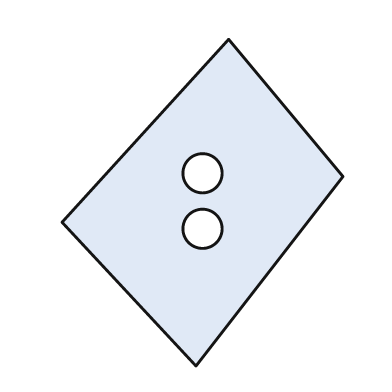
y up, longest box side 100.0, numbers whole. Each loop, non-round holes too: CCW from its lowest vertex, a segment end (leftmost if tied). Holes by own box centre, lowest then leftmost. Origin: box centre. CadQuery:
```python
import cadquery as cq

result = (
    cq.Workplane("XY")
    .moveTo(-2.0, -50.0)
    .lineTo(43.0, 8.0)
    .lineTo(8.0, 50.0)
    .lineTo(-43.0, -6.0)
    .close()
    .moveTo(0.0, -8.0)
    .circle(6.0)
    .moveTo(0.0, 9.0)
    .circle(6.0)
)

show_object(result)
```